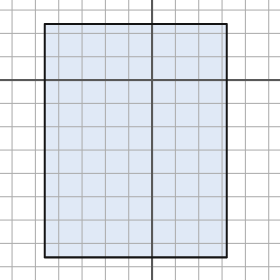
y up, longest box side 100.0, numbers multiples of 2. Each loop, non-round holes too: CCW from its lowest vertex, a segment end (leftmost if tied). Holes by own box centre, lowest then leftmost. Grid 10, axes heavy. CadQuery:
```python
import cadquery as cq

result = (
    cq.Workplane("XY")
    .moveTo(-46.0, -76.0)
    .lineTo(32.0, -76.0)
    .lineTo(32.0, 24.0)
    .lineTo(-46.0, 24.0)
    .close()
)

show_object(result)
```